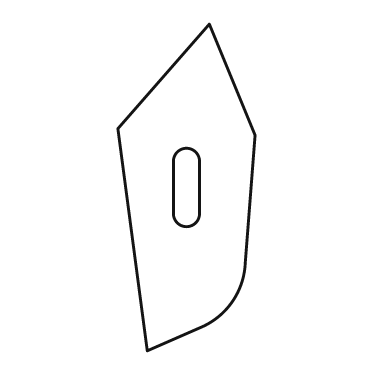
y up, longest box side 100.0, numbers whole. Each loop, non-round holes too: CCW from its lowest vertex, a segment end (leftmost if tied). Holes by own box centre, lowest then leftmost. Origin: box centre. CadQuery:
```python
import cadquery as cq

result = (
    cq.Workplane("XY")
    .moveTo(-12.0, -50.0)
    .lineTo(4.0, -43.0)
    .threePointArc((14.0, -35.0), (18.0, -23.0))
    .lineTo(21.0, 16.0)
    .lineTo(7.0, 50.0)
    .lineTo(-21.0, 18.0)
    .close()
    .moveTo(-4.0, -8.0)
    .threePointArc((0.0, -12.0), (4.0, -8.0))
    .lineTo(4.0, 8.0)
    .threePointArc((0.0, 12.0), (-4.0, 8.0))
    .close()
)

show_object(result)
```